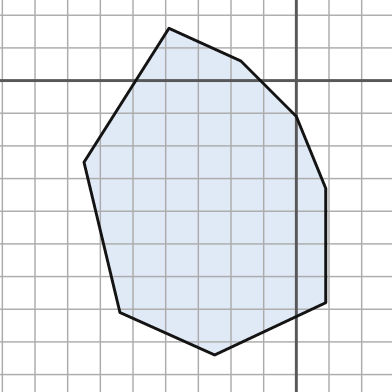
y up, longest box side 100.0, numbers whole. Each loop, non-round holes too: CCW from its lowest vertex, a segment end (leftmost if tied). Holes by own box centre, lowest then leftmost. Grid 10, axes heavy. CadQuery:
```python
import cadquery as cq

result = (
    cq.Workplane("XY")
    .moveTo(-25.0, -84.0)
    .lineTo(9.0, -68.0)
    .lineTo(9.0, -33.0)
    .lineTo(0.0, -11.0)
    .lineTo(-17.0, 6.0)
    .lineTo(-39.0, 16.0)
    .lineTo(-65.0, -25.0)
    .lineTo(-54.0, -71.0)
    .close()
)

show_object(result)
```